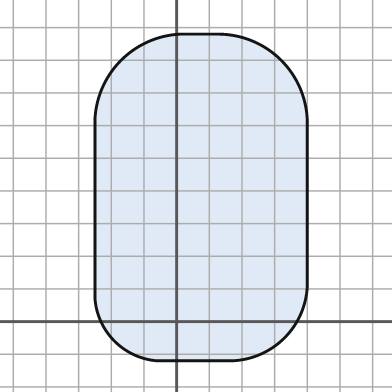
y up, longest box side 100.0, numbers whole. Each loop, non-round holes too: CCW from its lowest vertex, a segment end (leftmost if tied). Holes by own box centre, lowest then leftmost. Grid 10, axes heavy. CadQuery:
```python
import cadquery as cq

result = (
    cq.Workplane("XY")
    .moveTo(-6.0, -12.0)
    .lineTo(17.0, -12.0)
    .threePointArc((33.0, -5.0), (40.0, 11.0))
    .lineTo(40.0, 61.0)
    .threePointArc((32.0, 80.0), (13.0, 88.0))
    .lineTo(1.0, 88.0)
    .threePointArc((-17.0, 80.0), (-25.0, 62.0))
    .lineTo(-25.0, 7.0)
    .threePointArc((-19.0, -6.0), (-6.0, -12.0))
    .close()
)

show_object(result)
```